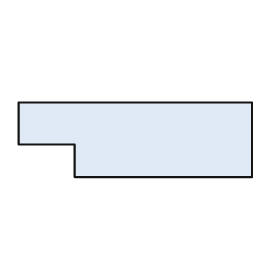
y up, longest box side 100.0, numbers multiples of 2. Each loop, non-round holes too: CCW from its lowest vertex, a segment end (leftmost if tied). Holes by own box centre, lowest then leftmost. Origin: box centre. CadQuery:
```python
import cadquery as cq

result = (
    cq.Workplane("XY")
    .moveTo(-26.0, -16.0)
    .lineTo(50.0, -16.0)
    .lineTo(50.0, 16.0)
    .lineTo(-50.0, 16.0)
    .lineTo(-50.0, -2.0)
    .lineTo(-26.0, -2.0)
    .close()
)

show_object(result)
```